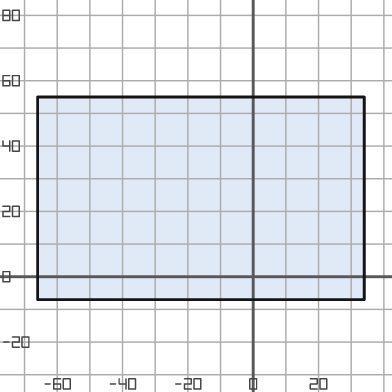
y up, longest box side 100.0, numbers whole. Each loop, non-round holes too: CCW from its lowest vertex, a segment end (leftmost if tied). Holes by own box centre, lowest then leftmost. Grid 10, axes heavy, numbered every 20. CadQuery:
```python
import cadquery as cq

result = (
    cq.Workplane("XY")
    .moveTo(-66.0, -7.0)
    .lineTo(34.0, -7.0)
    .lineTo(34.0, 55.0)
    .lineTo(-66.0, 55.0)
    .close()
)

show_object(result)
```